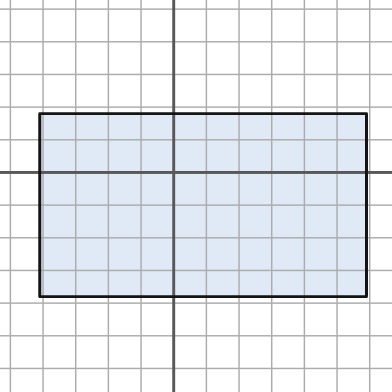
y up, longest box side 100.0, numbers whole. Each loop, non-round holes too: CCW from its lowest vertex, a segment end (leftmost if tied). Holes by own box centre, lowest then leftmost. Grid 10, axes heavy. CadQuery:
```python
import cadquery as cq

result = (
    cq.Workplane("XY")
    .moveTo(-41.0, -38.0)
    .lineTo(59.0, -38.0)
    .lineTo(59.0, 18.0)
    .lineTo(-41.0, 18.0)
    .close()
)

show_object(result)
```